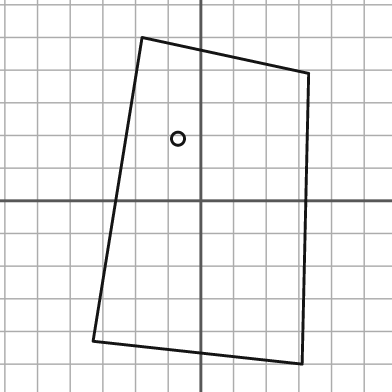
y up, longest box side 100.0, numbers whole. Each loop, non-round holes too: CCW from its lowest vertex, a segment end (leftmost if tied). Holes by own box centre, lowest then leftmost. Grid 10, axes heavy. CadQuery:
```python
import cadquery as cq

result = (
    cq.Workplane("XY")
    .moveTo(31.0, -50.0)
    .lineTo(33.0, 39.0)
    .lineTo(-18.0, 50.0)
    .lineTo(-33.0, -43.0)
    .close()
    .moveTo(-7.0, 19.0)
    .circle(2.0)
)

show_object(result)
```